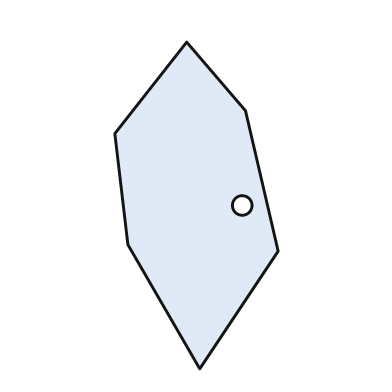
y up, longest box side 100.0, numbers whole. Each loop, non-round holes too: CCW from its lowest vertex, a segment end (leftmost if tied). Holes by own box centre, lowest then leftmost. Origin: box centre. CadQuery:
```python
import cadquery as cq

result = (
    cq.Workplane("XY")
    .moveTo(1.0, -50.0)
    .lineTo(25.0, -14.0)
    .lineTo(15.0, 29.0)
    .lineTo(-3.0, 50.0)
    .lineTo(-25.0, 22.0)
    .lineTo(-21.0, -12.0)
    .close()
    .moveTo(14.0, 0.0)
    .circle(3.0)
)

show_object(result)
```